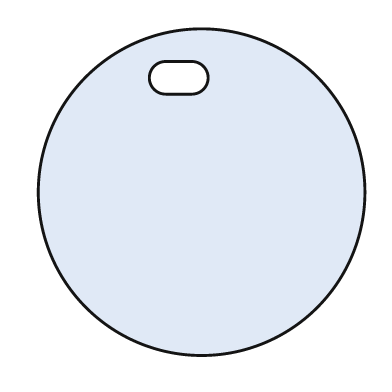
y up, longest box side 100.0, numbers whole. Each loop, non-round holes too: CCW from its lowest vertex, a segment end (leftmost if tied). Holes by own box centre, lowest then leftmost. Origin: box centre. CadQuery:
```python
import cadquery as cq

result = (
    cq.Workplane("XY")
    .moveTo(0.0, 0.0)
    .circle(50.0)
    .moveTo(-11.0, 30.0)
    .lineTo(-3.0, 30.0)
    .threePointArc((2.0, 35.0), (-3.0, 40.0))
    .lineTo(-11.0, 40.0)
    .threePointArc((-16.0, 35.0), (-11.0, 30.0))
    .close()
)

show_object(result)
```